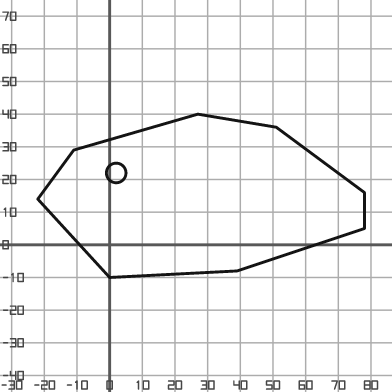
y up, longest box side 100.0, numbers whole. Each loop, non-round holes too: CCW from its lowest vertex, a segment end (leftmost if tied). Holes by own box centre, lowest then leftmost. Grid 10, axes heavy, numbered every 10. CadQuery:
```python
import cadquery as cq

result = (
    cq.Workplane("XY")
    .moveTo(0.0, -10.0)
    .lineTo(39.0, -8.0)
    .lineTo(78.0, 5.0)
    .lineTo(78.0, 16.0)
    .lineTo(51.0, 36.0)
    .lineTo(27.0, 40.0)
    .lineTo(-11.0, 29.0)
    .lineTo(-22.0, 14.0)
    .close()
    .moveTo(2.0, 22.0)
    .circle(3.0)
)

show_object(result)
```